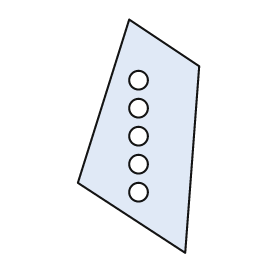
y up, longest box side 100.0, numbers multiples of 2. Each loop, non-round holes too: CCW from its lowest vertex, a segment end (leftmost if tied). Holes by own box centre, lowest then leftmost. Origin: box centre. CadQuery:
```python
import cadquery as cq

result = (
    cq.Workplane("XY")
    .moveTo(20.0, -50.0)
    .lineTo(26.0, 30.0)
    .lineTo(-4.0, 50.0)
    .lineTo(-26.0, -20.0)
    .close()
    .moveTo(0.0, -24.0)
    .circle(4.0)
    .moveTo(0.0, -12.0)
    .circle(4.0)
    .moveTo(0.0, 0.0)
    .circle(4.0)
    .moveTo(0.0, 12.0)
    .circle(4.0)
    .moveTo(0.0, 24.0)
    .circle(4.0)
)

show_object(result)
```